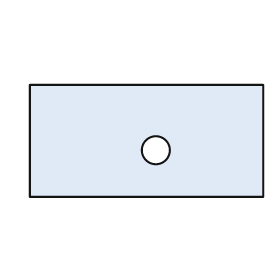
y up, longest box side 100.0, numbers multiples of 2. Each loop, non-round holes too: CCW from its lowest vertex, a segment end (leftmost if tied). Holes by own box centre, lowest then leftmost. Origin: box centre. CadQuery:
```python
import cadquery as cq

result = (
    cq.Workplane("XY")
    .moveTo(-50.0, -24.0)
    .lineTo(50.0, -24.0)
    .lineTo(50.0, 24.0)
    .lineTo(-50.0, 24.0)
    .close()
    .moveTo(4.0, -4.0)
    .circle(6.0)
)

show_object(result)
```